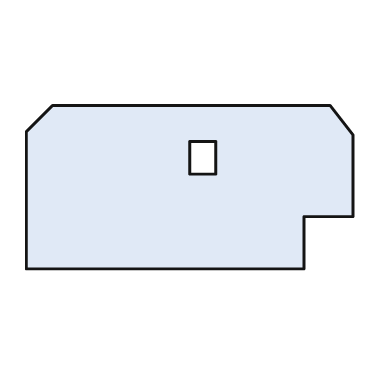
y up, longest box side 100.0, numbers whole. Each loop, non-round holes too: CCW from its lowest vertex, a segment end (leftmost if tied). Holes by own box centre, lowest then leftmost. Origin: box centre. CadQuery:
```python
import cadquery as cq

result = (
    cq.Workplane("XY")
    .moveTo(-50.0, -25.0)
    .lineTo(35.0, -25.0)
    .lineTo(35.0, -9.0)
    .lineTo(50.0, -9.0)
    .lineTo(50.0, 16.0)
    .lineTo(43.0, 25.0)
    .lineTo(-42.0, 25.0)
    .lineTo(-50.0, 17.0)
    .close()
    .moveTo(0.0, 4.0)
    .lineTo(8.0, 4.0)
    .lineTo(8.0, 14.0)
    .lineTo(0.0, 14.0)
    .close()
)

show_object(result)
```